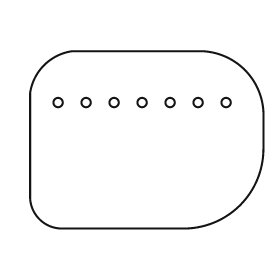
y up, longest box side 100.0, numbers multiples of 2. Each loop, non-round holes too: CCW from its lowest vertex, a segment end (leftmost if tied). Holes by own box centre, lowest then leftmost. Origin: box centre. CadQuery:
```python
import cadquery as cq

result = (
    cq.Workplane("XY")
    .moveTo(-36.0, -38.0)
    .lineTo(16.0, -38.0)
    .threePointArc((40.0, -28.0), (50.0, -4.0))
    .lineTo(50.0, 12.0)
    .threePointArc((42.0, 30.0), (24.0, 38.0))
    .lineTo(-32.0, 38.0)
    .threePointArc((-44.0, 32.0), (-50.0, 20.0))
    .lineTo(-50.0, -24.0)
    .threePointArc((-46.0, -34.0), (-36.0, -38.0))
    .close()
    .moveTo(-38.0, 16.0)
    .circle(2.0)
    .moveTo(-26.0, 16.0)
    .circle(2.0)
    .moveTo(-14.0, 16.0)
    .circle(2.0)
    .moveTo(-2.0, 16.0)
    .circle(2.0)
    .moveTo(10.0, 16.0)
    .circle(2.0)
    .moveTo(22.0, 16.0)
    .circle(2.0)
    .moveTo(34.0, 16.0)
    .circle(2.0)
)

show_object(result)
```